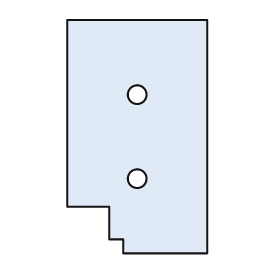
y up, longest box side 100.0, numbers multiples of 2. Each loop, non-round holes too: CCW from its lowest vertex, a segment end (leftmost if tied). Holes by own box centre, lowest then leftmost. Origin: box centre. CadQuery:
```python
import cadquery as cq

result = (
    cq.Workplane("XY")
    .moveTo(-6.0, -50.0)
    .lineTo(30.0, -50.0)
    .lineTo(30.0, 50.0)
    .lineTo(-30.0, 50.0)
    .lineTo(-30.0, -30.0)
    .lineTo(-12.0, -30.0)
    .lineTo(-12.0, -44.0)
    .lineTo(-6.0, -44.0)
    .close()
    .moveTo(0.0, -18.0)
    .circle(4.0)
    .moveTo(0.0, 18.0)
    .circle(4.0)
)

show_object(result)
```